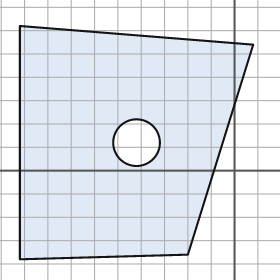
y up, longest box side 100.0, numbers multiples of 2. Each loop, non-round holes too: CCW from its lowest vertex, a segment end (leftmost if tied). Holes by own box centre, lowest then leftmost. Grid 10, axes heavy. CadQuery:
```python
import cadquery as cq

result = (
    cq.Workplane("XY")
    .moveTo(-92.0, -38.0)
    .lineTo(-20.0, -36.0)
    .lineTo(8.0, 54.0)
    .lineTo(-92.0, 62.0)
    .close()
    .moveTo(-42.0, 12.0)
    .circle(10.0)
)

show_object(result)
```